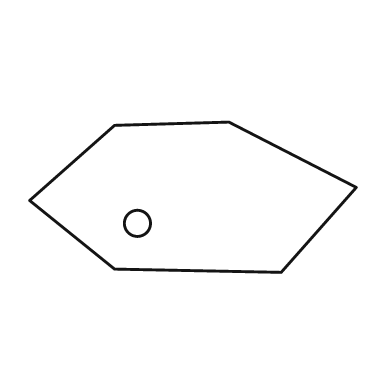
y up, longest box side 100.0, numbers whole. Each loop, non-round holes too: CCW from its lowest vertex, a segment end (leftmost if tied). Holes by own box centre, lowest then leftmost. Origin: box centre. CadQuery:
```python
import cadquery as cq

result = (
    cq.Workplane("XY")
    .moveTo(27.0, -23.0)
    .lineTo(50.0, 3.0)
    .lineTo(11.0, 23.0)
    .lineTo(-24.0, 22.0)
    .lineTo(-50.0, -1.0)
    .lineTo(-24.0, -22.0)
    .close()
    .moveTo(-17.0, -8.0)
    .circle(4.0)
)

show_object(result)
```